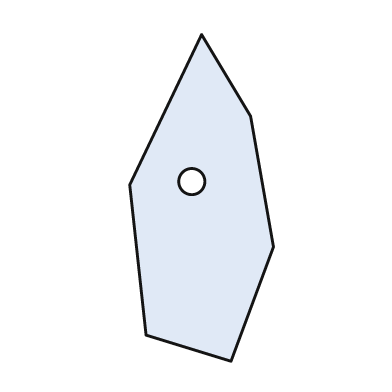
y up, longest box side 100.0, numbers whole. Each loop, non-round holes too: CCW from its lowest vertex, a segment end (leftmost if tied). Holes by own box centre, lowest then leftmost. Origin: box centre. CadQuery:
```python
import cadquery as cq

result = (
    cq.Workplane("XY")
    .moveTo(9.0, -50.0)
    .lineTo(22.0, -15.0)
    .lineTo(15.0, 25.0)
    .lineTo(0.0, 50.0)
    .lineTo(-22.0, 4.0)
    .lineTo(-17.0, -42.0)
    .close()
    .moveTo(-3.0, 5.0)
    .circle(4.0)
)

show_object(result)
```